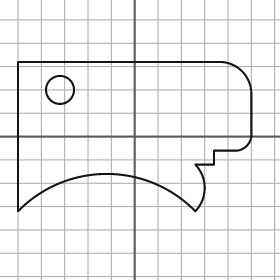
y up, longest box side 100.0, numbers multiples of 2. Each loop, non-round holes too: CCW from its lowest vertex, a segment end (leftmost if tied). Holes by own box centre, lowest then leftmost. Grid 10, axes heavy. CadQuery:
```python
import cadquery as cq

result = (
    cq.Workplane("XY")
    .moveTo(-50.0, -32.0)
    .threePointArc((-12.0, -16.0), (26.0, -32.0))
    .threePointArc((30.0, -22.0), (26.0, -12.0))
    .lineTo(34.0, -12.0)
    .lineTo(34.0, -6.0)
    .lineTo(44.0, -6.0)
    .threePointArc((48.0, -4.0), (50.0, 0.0))
    .lineTo(50.0, 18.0)
    .threePointArc((46.0, 28.0), (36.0, 32.0))
    .lineTo(-50.0, 32.0)
    .close()
    .moveTo(-32.0, 20.0)
    .circle(6.0)
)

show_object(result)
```